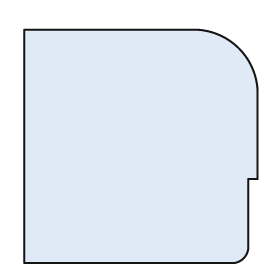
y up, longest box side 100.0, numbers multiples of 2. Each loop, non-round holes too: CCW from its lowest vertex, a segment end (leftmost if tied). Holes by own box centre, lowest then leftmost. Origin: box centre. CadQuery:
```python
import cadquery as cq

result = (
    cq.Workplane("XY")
    .moveTo(-50.0, -50.0)
    .lineTo(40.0, -50.0)
    .threePointArc((44.0, -48.0), (46.0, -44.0))
    .lineTo(46.0, -14.0)
    .lineTo(50.0, -14.0)
    .lineTo(50.0, 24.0)
    .threePointArc((42.0, 42.0), (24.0, 50.0))
    .lineTo(-50.0, 50.0)
    .close()
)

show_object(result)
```